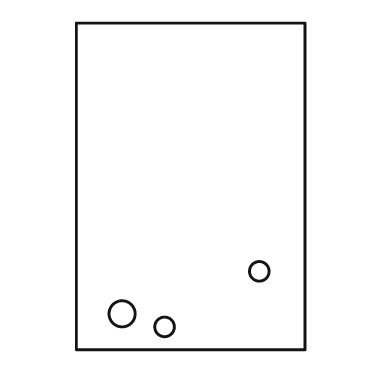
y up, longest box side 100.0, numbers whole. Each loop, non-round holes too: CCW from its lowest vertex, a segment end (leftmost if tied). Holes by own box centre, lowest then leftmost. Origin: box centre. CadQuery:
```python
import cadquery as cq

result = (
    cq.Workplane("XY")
    .moveTo(-35.0, -50.0)
    .lineTo(35.0, -50.0)
    .lineTo(35.0, 50.0)
    .lineTo(-35.0, 50.0)
    .close()
    .moveTo(-8.0, -43.0)
    .circle(3.0)
    .moveTo(-21.0, -39.0)
    .circle(4.0)
    .moveTo(21.0, -26.0)
    .circle(3.0)
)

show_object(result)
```